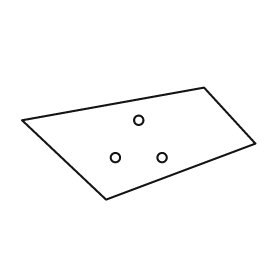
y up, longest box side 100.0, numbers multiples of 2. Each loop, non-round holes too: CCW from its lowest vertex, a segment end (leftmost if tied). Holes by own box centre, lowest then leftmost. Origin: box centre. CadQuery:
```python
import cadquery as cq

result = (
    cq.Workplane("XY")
    .moveTo(-14.0, -24.0)
    .lineTo(50.0, 0.0)
    .lineTo(28.0, 24.0)
    .lineTo(-50.0, 10.0)
    .close()
    .moveTo(-10.0, -6.0)
    .circle(2.0)
    .moveTo(10.0, -6.0)
    .circle(2.0)
    .moveTo(0.0, 10.0)
    .circle(2.0)
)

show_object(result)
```